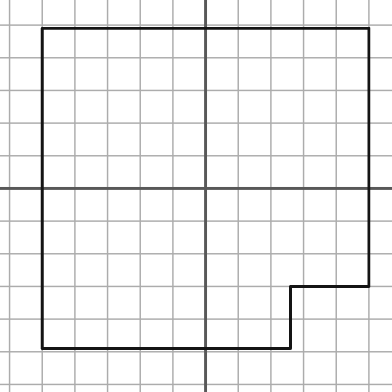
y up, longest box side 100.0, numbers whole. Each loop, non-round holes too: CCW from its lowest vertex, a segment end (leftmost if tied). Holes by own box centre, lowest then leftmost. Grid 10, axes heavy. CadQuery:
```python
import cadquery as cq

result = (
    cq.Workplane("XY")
    .moveTo(-50.0, -49.0)
    .lineTo(26.0, -49.0)
    .lineTo(26.0, -30.0)
    .lineTo(50.0, -30.0)
    .lineTo(50.0, 49.0)
    .lineTo(-50.0, 49.0)
    .close()
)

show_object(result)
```